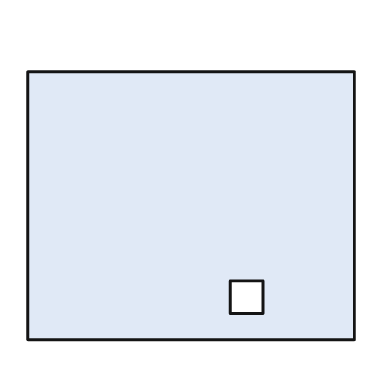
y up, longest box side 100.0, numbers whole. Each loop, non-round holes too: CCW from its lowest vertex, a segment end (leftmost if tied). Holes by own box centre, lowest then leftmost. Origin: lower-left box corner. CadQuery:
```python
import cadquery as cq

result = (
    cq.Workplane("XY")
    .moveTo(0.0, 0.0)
    .lineTo(100.0, 0.0)
    .lineTo(100.0, 82.0)
    .lineTo(0.0, 82.0)
    .close()
    .moveTo(62.0, 8.0)
    .lineTo(72.0, 8.0)
    .lineTo(72.0, 18.0)
    .lineTo(62.0, 18.0)
    .close()
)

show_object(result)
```